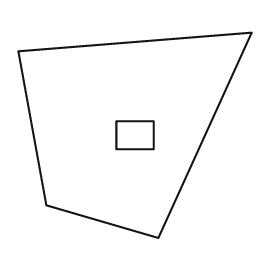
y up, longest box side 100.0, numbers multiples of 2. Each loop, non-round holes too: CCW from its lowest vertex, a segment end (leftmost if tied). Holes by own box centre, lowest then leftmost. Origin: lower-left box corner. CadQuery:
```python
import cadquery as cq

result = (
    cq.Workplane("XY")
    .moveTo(60.0, 0.0)
    .lineTo(100.0, 88.0)
    .lineTo(0.0, 80.0)
    .lineTo(12.0, 14.0)
    .close()
    .moveTo(42.0, 38.0)
    .lineTo(58.0, 38.0)
    .lineTo(58.0, 50.0)
    .lineTo(42.0, 50.0)
    .close()
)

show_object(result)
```